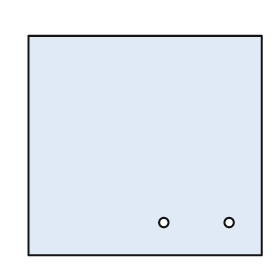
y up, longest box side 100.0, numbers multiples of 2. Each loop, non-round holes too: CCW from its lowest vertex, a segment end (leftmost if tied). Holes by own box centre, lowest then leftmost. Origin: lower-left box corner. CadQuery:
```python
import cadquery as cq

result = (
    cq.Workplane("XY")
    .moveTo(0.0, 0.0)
    .lineTo(100.0, 0.0)
    .lineTo(100.0, 94.0)
    .lineTo(0.0, 94.0)
    .close()
    .moveTo(58.0, 14.0)
    .circle(2.0)
    .moveTo(86.0, 14.0)
    .circle(2.0)
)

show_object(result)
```